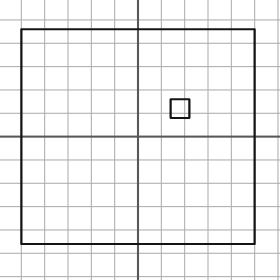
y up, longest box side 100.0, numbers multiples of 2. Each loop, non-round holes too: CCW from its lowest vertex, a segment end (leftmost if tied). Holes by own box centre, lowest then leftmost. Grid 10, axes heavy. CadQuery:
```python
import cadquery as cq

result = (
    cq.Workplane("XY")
    .moveTo(-50.0, -46.0)
    .lineTo(50.0, -46.0)
    .lineTo(50.0, 46.0)
    .lineTo(-50.0, 46.0)
    .close()
    .moveTo(14.0, 8.0)
    .lineTo(22.0, 8.0)
    .lineTo(22.0, 16.0)
    .lineTo(14.0, 16.0)
    .close()
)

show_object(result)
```